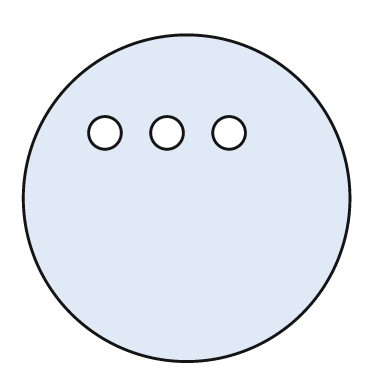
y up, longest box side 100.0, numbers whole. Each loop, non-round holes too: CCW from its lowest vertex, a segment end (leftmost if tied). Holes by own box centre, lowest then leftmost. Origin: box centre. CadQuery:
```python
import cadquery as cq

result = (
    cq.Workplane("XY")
    .moveTo(0.0, 0.0)
    .circle(50.0)
    .moveTo(-25.0, 20.0)
    .circle(5.0)
    .moveTo(-6.0, 20.0)
    .circle(5.0)
    .moveTo(13.0, 20.0)
    .circle(5.0)
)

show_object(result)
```